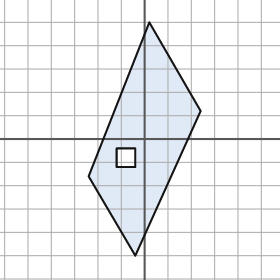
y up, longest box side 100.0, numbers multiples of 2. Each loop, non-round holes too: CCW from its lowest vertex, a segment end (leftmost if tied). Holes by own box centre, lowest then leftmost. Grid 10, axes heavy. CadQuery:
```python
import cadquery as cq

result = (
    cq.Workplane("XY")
    .moveTo(-4.0, -50.0)
    .lineTo(24.0, 12.0)
    .lineTo(2.0, 50.0)
    .lineTo(-24.0, -16.0)
    .close()
    .moveTo(-12.0, -12.0)
    .lineTo(-4.0, -12.0)
    .lineTo(-4.0, -4.0)
    .lineTo(-12.0, -4.0)
    .close()
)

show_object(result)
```